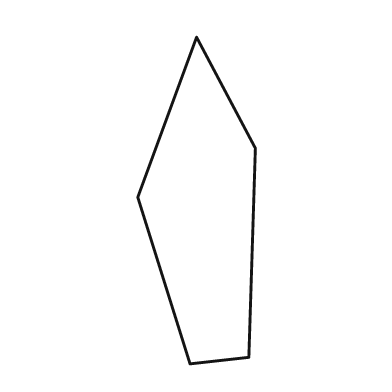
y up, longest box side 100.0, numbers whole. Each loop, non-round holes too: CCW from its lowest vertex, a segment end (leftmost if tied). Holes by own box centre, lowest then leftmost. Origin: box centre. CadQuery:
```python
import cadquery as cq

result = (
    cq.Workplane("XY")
    .moveTo(-2.0, -50.0)
    .lineTo(16.0, -48.0)
    .lineTo(18.0, 16.0)
    .lineTo(0.0, 50.0)
    .lineTo(-18.0, 1.0)
    .close()
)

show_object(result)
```